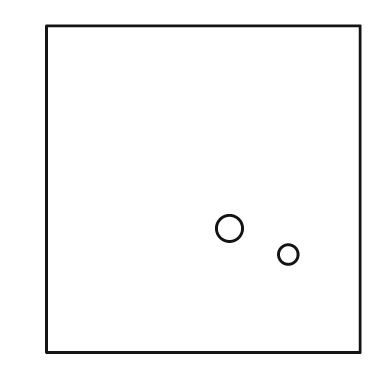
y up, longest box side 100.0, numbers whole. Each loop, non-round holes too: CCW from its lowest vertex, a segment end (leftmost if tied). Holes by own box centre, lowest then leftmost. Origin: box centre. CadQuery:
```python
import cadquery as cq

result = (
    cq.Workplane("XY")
    .moveTo(-48.0, -50.0)
    .lineTo(48.0, -50.0)
    .lineTo(48.0, 50.0)
    .lineTo(-48.0, 50.0)
    .close()
    .moveTo(26.0, -20.0)
    .circle(3.0)
    .moveTo(8.0, -12.0)
    .circle(4.0)
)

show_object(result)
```